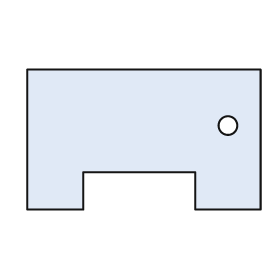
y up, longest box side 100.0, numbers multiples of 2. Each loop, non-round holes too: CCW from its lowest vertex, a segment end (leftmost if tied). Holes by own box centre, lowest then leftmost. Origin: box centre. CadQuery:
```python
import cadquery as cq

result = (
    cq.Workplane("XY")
    .moveTo(-50.0, -30.0)
    .lineTo(-26.0, -30.0)
    .lineTo(-26.0, -14.0)
    .lineTo(22.0, -14.0)
    .lineTo(22.0, -30.0)
    .lineTo(50.0, -30.0)
    .lineTo(50.0, 30.0)
    .lineTo(-50.0, 30.0)
    .close()
    .moveTo(36.0, 6.0)
    .circle(4.0)
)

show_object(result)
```